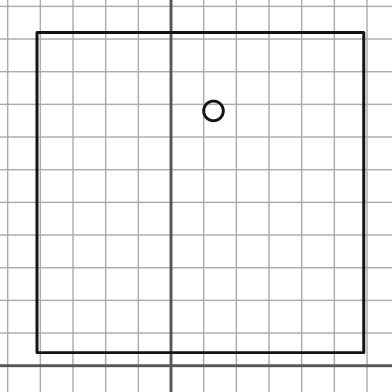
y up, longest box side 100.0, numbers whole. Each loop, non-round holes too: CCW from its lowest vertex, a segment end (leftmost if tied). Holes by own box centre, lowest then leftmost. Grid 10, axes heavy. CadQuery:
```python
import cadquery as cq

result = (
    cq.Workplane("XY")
    .moveTo(-41.0, 4.0)
    .lineTo(59.0, 4.0)
    .lineTo(59.0, 102.0)
    .lineTo(-41.0, 102.0)
    .close()
    .moveTo(13.0, 78.0)
    .circle(3.0)
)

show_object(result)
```